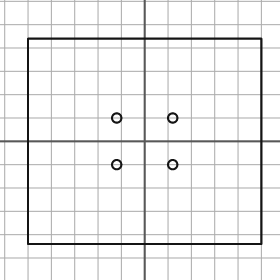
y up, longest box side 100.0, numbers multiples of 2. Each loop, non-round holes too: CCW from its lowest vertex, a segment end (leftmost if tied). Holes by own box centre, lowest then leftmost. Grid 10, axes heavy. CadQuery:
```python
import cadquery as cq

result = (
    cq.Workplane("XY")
    .moveTo(-50.0, -44.0)
    .lineTo(50.0, -44.0)
    .lineTo(50.0, 44.0)
    .lineTo(-50.0, 44.0)
    .close()
    .moveTo(-12.0, -10.0)
    .circle(2.0)
    .moveTo(12.0, -10.0)
    .circle(2.0)
    .moveTo(-12.0, 10.0)
    .circle(2.0)
    .moveTo(12.0, 10.0)
    .circle(2.0)
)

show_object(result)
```